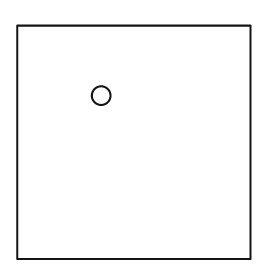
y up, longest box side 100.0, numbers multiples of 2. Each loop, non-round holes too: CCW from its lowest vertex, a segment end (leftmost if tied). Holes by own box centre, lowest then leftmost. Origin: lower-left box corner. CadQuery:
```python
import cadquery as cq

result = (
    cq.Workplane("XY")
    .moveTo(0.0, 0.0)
    .lineTo(100.0, 0.0)
    .lineTo(100.0, 100.0)
    .lineTo(0.0, 100.0)
    .close()
    .moveTo(36.0, 70.0)
    .circle(4.0)
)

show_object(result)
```